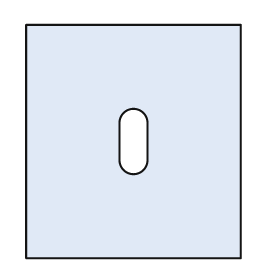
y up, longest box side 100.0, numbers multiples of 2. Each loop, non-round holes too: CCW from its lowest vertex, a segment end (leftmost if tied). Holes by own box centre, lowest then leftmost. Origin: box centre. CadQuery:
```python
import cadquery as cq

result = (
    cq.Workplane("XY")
    .moveTo(-46.0, -50.0)
    .lineTo(46.0, -50.0)
    .lineTo(46.0, 50.0)
    .lineTo(-46.0, 50.0)
    .close()
    .moveTo(-6.0, -8.0)
    .threePointArc((0.0, -14.0), (6.0, -8.0))
    .lineTo(6.0, 8.0)
    .threePointArc((0.0, 14.0), (-6.0, 8.0))
    .close()
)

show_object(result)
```